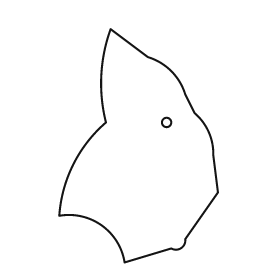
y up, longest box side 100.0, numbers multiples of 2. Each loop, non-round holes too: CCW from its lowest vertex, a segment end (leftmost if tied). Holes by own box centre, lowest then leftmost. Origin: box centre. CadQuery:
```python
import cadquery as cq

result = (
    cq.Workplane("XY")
    .moveTo(-6.0, -50.0)
    .lineTo(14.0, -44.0)
    .threePointArc((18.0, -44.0), (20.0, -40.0))
    .lineTo(34.0, -20.0)
    .lineTo(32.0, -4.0)
    .threePointArc((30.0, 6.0), (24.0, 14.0))
    .lineTo(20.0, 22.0)
    .threePointArc((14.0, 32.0), (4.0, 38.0))
    .lineTo(-12.0, 50.0)
    .threePointArc((-16.0, 30.0), (-14.0, 10.0))
    .threePointArc((-28.0, -8.0), (-34.0, -30.0))
    .threePointArc((-16.0, -34.0), (-6.0, -50.0))
    .close()
    .moveTo(12.0, 10.0)
    .circle(2.0)
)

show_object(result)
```